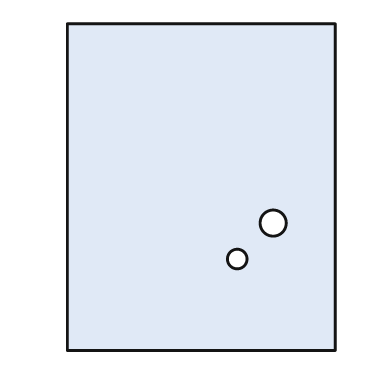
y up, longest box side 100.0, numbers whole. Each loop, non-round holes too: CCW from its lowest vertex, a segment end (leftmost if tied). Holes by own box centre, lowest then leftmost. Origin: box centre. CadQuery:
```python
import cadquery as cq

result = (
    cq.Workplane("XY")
    .moveTo(-41.0, -50.0)
    .lineTo(41.0, -50.0)
    .lineTo(41.0, 50.0)
    .lineTo(-41.0, 50.0)
    .close()
    .moveTo(11.0, -22.0)
    .circle(3.0)
    .moveTo(22.0, -11.0)
    .circle(4.0)
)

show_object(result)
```